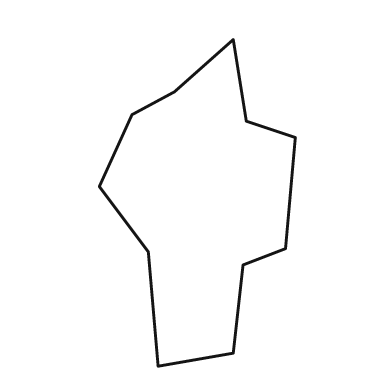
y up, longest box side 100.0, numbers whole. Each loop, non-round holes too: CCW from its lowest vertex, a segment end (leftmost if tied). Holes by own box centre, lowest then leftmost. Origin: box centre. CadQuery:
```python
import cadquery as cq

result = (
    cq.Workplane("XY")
    .moveTo(-12.0, -50.0)
    .lineTo(11.0, -46.0)
    .lineTo(14.0, -19.0)
    .lineTo(27.0, -14.0)
    .lineTo(30.0, 20.0)
    .lineTo(15.0, 25.0)
    .lineTo(11.0, 50.0)
    .lineTo(-7.0, 34.0)
    .lineTo(-20.0, 27.0)
    .lineTo(-30.0, 5.0)
    .lineTo(-15.0, -15.0)
    .close()
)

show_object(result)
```